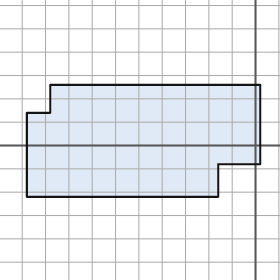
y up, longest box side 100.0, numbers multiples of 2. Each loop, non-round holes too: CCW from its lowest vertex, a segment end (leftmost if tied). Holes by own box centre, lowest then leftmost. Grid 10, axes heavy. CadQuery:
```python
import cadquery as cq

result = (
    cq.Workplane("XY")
    .moveTo(-98.0, -22.0)
    .lineTo(-16.0, -22.0)
    .lineTo(-16.0, -8.0)
    .lineTo(2.0, -8.0)
    .lineTo(2.0, 26.0)
    .lineTo(-88.0, 26.0)
    .lineTo(-88.0, 14.0)
    .lineTo(-98.0, 14.0)
    .close()
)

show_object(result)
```